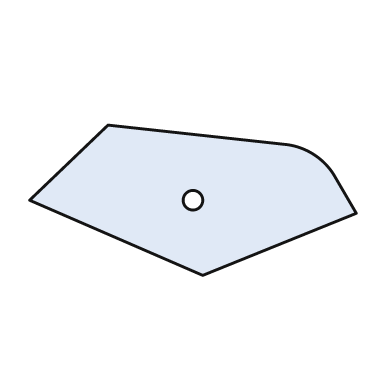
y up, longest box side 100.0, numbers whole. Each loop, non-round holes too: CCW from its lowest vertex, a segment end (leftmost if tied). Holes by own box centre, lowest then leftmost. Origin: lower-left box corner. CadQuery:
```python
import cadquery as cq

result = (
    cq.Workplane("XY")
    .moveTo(53.0, 0.0)
    .lineTo(100.0, 19.0)
    .lineTo(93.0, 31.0)
    .threePointArc((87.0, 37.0), (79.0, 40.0))
    .lineTo(24.0, 46.0)
    .lineTo(0.0, 23.0)
    .close()
    .moveTo(50.0, 23.0)
    .circle(3.0)
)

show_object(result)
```